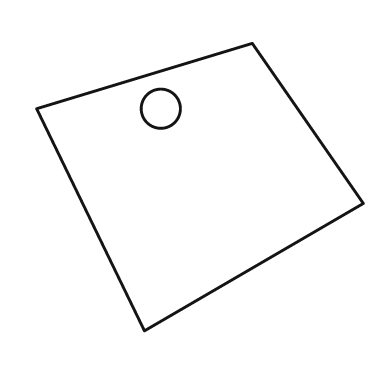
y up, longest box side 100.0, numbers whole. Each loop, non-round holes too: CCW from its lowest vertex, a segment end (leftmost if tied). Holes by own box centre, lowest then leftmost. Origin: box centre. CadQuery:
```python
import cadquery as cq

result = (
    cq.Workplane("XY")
    .moveTo(-17.0, -44.0)
    .lineTo(50.0, -5.0)
    .lineTo(16.0, 44.0)
    .lineTo(-50.0, 24.0)
    .close()
    .moveTo(-12.0, 24.0)
    .circle(6.0)
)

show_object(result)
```